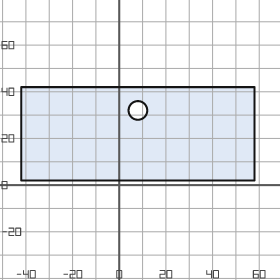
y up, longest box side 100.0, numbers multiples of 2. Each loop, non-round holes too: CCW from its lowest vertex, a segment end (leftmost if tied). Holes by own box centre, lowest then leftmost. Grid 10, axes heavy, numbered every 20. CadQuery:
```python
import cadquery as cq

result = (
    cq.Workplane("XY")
    .moveTo(-42.0, 2.0)
    .lineTo(58.0, 2.0)
    .lineTo(58.0, 42.0)
    .lineTo(-42.0, 42.0)
    .close()
    .moveTo(8.0, 32.0)
    .circle(4.0)
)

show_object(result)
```